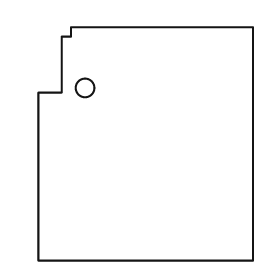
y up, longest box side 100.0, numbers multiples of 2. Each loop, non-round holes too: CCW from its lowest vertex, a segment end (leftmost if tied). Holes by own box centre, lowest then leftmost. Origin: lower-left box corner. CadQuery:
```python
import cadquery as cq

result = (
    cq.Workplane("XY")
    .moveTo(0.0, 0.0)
    .lineTo(92.0, 0.0)
    .lineTo(92.0, 100.0)
    .lineTo(14.0, 100.0)
    .lineTo(14.0, 96.0)
    .lineTo(10.0, 96.0)
    .lineTo(10.0, 72.0)
    .lineTo(0.0, 72.0)
    .close()
    .moveTo(20.0, 74.0)
    .circle(4.0)
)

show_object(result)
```